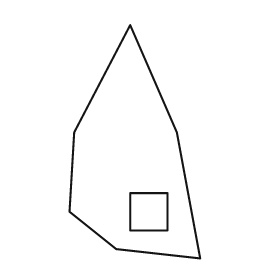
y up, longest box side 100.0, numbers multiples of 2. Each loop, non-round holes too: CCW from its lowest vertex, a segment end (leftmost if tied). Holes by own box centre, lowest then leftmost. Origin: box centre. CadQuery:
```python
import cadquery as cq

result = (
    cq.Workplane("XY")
    .moveTo(28.0, -50.0)
    .lineTo(18.0, 4.0)
    .lineTo(-2.0, 50.0)
    .lineTo(-26.0, 4.0)
    .lineTo(-28.0, -30.0)
    .lineTo(-8.0, -46.0)
    .close()
    .moveTo(-2.0, -38.0)
    .lineTo(14.0, -38.0)
    .lineTo(14.0, -22.0)
    .lineTo(-2.0, -22.0)
    .close()
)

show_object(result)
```